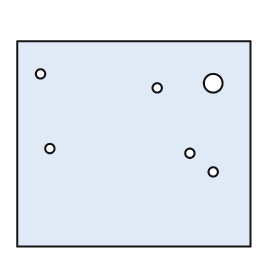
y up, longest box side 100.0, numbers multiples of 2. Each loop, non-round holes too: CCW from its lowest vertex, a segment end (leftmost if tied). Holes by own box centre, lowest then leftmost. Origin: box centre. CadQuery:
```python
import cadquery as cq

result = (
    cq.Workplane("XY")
    .moveTo(-50.0, -44.0)
    .lineTo(50.0, -44.0)
    .lineTo(50.0, 44.0)
    .lineTo(-50.0, 44.0)
    .close()
    .moveTo(34.0, -12.0)
    .circle(2.0)
    .moveTo(24.0, -4.0)
    .circle(2.0)
    .moveTo(-36.0, -2.0)
    .circle(2.0)
    .moveTo(10.0, 24.0)
    .circle(2.0)
    .moveTo(34.0, 26.0)
    .circle(4.0)
    .moveTo(-40.0, 30.0)
    .circle(2.0)
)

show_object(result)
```